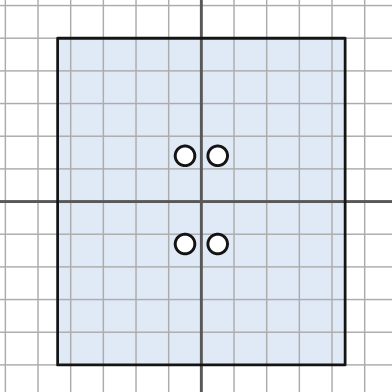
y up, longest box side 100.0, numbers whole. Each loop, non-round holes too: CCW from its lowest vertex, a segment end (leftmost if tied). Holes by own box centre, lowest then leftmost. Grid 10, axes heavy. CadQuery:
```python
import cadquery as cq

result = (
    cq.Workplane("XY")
    .moveTo(-44.0, -50.0)
    .lineTo(44.0, -50.0)
    .lineTo(44.0, 50.0)
    .lineTo(-44.0, 50.0)
    .close()
    .moveTo(-5.0, -13.0)
    .circle(3.0)
    .moveTo(5.0, -13.0)
    .circle(3.0)
    .moveTo(-5.0, 14.0)
    .circle(3.0)
    .moveTo(5.0, 14.0)
    .circle(3.0)
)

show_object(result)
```